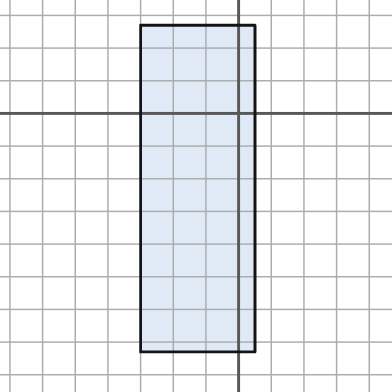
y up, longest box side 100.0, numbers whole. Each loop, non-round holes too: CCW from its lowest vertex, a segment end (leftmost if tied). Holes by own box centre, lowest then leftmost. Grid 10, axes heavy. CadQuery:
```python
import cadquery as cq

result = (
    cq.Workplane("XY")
    .moveTo(-30.0, -73.0)
    .lineTo(5.0, -73.0)
    .lineTo(5.0, 27.0)
    .lineTo(-30.0, 27.0)
    .close()
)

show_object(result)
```